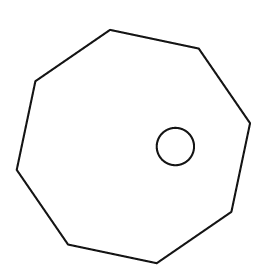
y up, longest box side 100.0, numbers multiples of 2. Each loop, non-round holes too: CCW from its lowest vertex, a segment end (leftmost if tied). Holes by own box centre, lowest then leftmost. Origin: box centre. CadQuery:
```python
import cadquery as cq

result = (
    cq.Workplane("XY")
    .moveTo(10.0, -50.0)
    .lineTo(42.0, -28.0)
    .lineTo(50.0, 10.0)
    .lineTo(28.0, 42.0)
    .lineTo(-10.0, 50.0)
    .lineTo(-42.0, 28.0)
    .lineTo(-50.0, -10.0)
    .lineTo(-28.0, -42.0)
    .close()
    .moveTo(18.0, 0.0)
    .circle(8.0)
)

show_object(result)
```